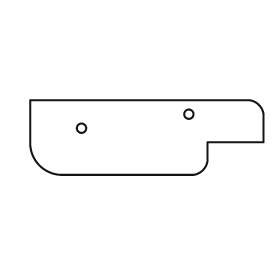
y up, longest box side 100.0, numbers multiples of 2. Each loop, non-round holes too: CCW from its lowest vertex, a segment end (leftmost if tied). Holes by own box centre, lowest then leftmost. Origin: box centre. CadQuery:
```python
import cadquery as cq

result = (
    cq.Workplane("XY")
    .moveTo(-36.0, -16.0)
    .lineTo(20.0, -16.0)
    .threePointArc((24.0, -14.0), (26.0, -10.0))
    .lineTo(26.0, -2.0)
    .lineTo(50.0, -2.0)
    .lineTo(50.0, 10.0)
    .threePointArc((48.0, 14.0), (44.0, 16.0))
    .lineTo(-50.0, 16.0)
    .lineTo(-50.0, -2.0)
    .threePointArc((-46.0, -12.0), (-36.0, -16.0))
    .close()
    .moveTo(-28.0, 4.0)
    .circle(2.0)
    .moveTo(18.0, 10.0)
    .circle(2.0)
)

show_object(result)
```